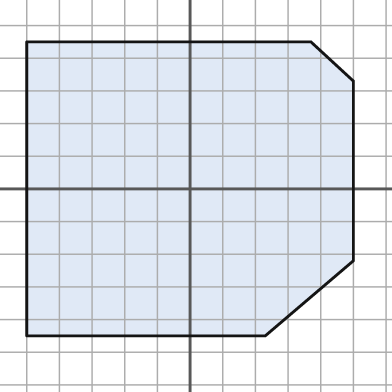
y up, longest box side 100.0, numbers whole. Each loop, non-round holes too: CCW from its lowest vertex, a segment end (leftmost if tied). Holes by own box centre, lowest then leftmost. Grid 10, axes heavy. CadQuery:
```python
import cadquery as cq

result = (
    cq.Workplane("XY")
    .moveTo(-50.0, -45.0)
    .lineTo(23.0, -45.0)
    .lineTo(50.0, -22.0)
    .lineTo(50.0, 33.0)
    .lineTo(37.0, 45.0)
    .lineTo(-50.0, 45.0)
    .close()
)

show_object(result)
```